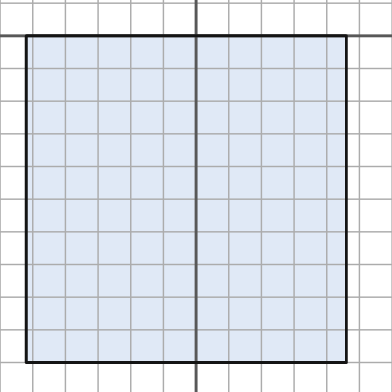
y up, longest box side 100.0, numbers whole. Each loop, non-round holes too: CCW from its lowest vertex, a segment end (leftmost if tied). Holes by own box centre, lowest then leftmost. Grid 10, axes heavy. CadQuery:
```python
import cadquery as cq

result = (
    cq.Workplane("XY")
    .moveTo(-52.0, -100.0)
    .lineTo(46.0, -100.0)
    .lineTo(46.0, 0.0)
    .lineTo(-52.0, 0.0)
    .close()
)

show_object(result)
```